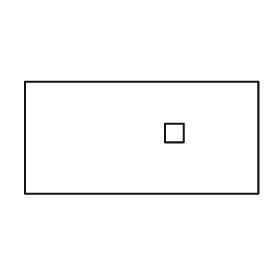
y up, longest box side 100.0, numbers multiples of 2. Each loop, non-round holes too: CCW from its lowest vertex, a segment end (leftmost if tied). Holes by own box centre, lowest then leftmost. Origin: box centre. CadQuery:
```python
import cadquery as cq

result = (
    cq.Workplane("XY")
    .moveTo(-50.0, -24.0)
    .lineTo(50.0, -24.0)
    .lineTo(50.0, 24.0)
    .lineTo(-50.0, 24.0)
    .close()
    .moveTo(10.0, -2.0)
    .lineTo(18.0, -2.0)
    .lineTo(18.0, 6.0)
    .lineTo(10.0, 6.0)
    .close()
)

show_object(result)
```